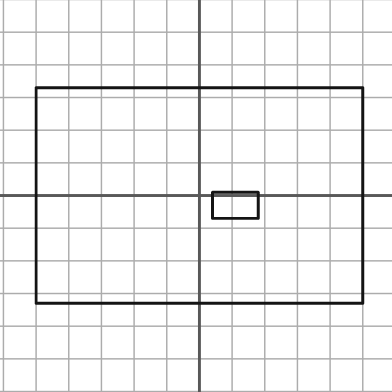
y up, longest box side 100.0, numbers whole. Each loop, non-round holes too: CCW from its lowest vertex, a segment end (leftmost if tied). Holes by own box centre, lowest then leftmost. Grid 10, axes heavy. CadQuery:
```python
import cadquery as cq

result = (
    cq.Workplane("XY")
    .moveTo(-50.0, -33.0)
    .lineTo(50.0, -33.0)
    .lineTo(50.0, 33.0)
    .lineTo(-50.0, 33.0)
    .close()
    .moveTo(4.0, -7.0)
    .lineTo(18.0, -7.0)
    .lineTo(18.0, 1.0)
    .lineTo(4.0, 1.0)
    .close()
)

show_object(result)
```